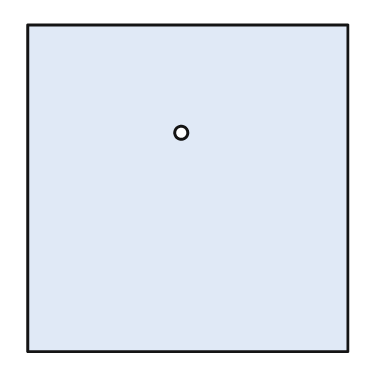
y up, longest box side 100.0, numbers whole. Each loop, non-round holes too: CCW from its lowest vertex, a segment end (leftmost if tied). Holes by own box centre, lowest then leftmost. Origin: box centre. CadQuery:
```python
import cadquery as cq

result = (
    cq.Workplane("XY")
    .moveTo(-49.0, -50.0)
    .lineTo(49.0, -50.0)
    .lineTo(49.0, 50.0)
    .lineTo(-49.0, 50.0)
    .close()
    .moveTo(-2.0, 17.0)
    .circle(2.0)
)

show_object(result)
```